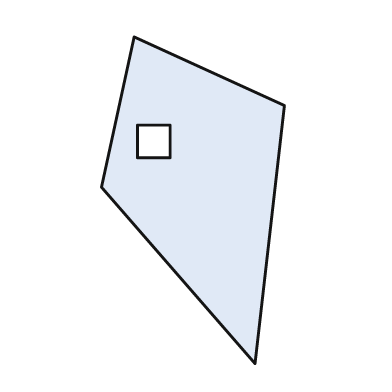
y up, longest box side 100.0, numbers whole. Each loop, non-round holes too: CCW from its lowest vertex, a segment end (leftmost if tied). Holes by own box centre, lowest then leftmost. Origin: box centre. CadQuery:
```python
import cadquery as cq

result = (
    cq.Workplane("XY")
    .moveTo(19.0, -50.0)
    .lineTo(28.0, 29.0)
    .lineTo(-18.0, 50.0)
    .lineTo(-28.0, 4.0)
    .close()
    .moveTo(-17.0, 13.0)
    .lineTo(-7.0, 13.0)
    .lineTo(-7.0, 23.0)
    .lineTo(-17.0, 23.0)
    .close()
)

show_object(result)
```